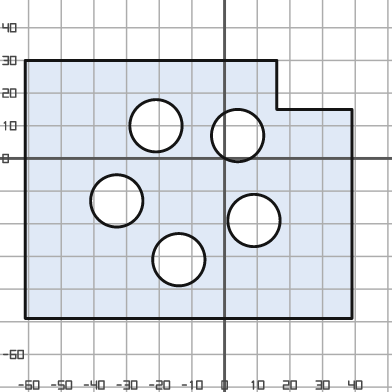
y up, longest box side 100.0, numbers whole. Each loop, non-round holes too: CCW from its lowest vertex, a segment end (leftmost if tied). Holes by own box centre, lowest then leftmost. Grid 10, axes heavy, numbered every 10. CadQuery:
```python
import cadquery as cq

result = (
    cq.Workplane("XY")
    .moveTo(-61.0, -49.0)
    .lineTo(39.0, -49.0)
    .lineTo(39.0, 15.0)
    .lineTo(16.0, 15.0)
    .lineTo(16.0, 30.0)
    .lineTo(-61.0, 30.0)
    .close()
    .moveTo(-14.0, -31.0)
    .circle(8.0)
    .moveTo(9.0, -19.0)
    .circle(8.0)
    .moveTo(-33.0, -13.0)
    .circle(8.0)
    .moveTo(4.0, 7.0)
    .circle(8.0)
    .moveTo(-21.0, 10.0)
    .circle(8.0)
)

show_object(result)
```